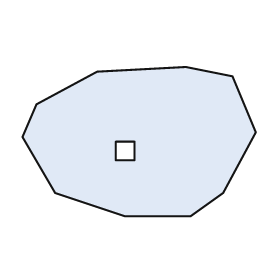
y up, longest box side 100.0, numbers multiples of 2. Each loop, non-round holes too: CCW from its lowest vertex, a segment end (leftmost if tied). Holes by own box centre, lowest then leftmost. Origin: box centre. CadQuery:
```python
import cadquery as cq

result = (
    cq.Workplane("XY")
    .moveTo(-6.0, -32.0)
    .lineTo(22.0, -32.0)
    .lineTo(36.0, -22.0)
    .lineTo(50.0, 4.0)
    .lineTo(40.0, 28.0)
    .lineTo(20.0, 32.0)
    .lineTo(-18.0, 30.0)
    .lineTo(-44.0, 16.0)
    .lineTo(-50.0, 2.0)
    .lineTo(-36.0, -22.0)
    .close()
    .moveTo(-10.0, -8.0)
    .lineTo(-2.0, -8.0)
    .lineTo(-2.0, 0.0)
    .lineTo(-10.0, 0.0)
    .close()
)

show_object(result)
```